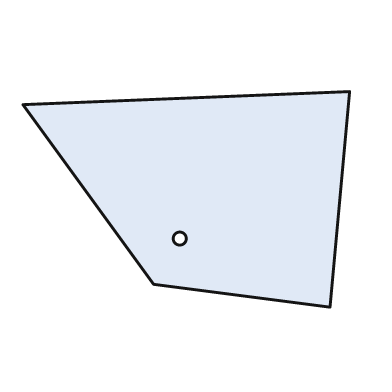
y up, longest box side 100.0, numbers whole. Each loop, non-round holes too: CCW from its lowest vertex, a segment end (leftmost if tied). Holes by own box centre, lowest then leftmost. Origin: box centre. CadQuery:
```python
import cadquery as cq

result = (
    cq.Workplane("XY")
    .moveTo(44.0, -33.0)
    .lineTo(50.0, 33.0)
    .lineTo(-50.0, 29.0)
    .lineTo(-10.0, -26.0)
    .close()
    .moveTo(-2.0, -12.0)
    .circle(2.0)
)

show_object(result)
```